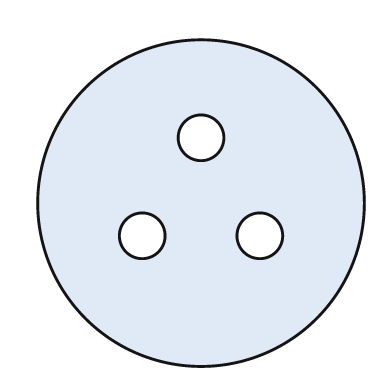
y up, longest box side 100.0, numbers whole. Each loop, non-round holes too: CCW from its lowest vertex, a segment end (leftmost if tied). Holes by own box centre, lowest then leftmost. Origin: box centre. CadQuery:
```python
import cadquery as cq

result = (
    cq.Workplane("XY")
    .moveTo(0.0, 0.0)
    .circle(50.0)
    .moveTo(-18.0, -10.0)
    .circle(7.0)
    .moveTo(18.0, -10.0)
    .circle(7.0)
    .moveTo(0.0, 20.0)
    .circle(7.0)
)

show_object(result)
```